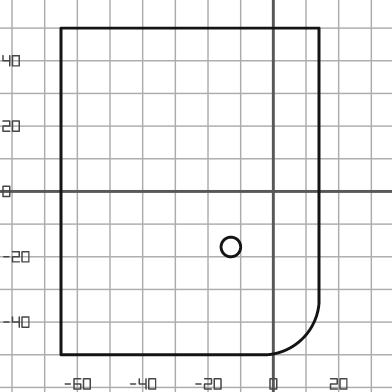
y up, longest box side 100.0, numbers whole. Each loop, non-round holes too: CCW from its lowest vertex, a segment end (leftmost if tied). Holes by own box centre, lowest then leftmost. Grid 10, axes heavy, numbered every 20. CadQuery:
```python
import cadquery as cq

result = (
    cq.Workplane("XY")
    .moveTo(-65.0, -50.0)
    .lineTo(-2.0, -50.0)
    .threePointArc((9.0, -45.0), (14.0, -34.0))
    .lineTo(14.0, 50.0)
    .lineTo(-65.0, 50.0)
    .close()
    .moveTo(-13.0, -17.0)
    .circle(3.0)
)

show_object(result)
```